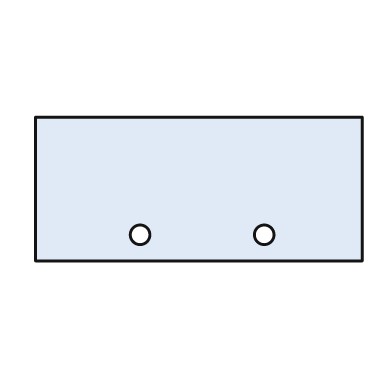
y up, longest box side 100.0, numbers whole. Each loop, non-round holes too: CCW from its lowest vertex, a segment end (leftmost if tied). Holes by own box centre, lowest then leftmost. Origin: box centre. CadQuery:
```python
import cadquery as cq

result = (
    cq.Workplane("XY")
    .moveTo(-50.0, -22.0)
    .lineTo(50.0, -22.0)
    .lineTo(50.0, 22.0)
    .lineTo(-50.0, 22.0)
    .close()
    .moveTo(-18.0, -14.0)
    .circle(3.0)
    .moveTo(20.0, -14.0)
    .circle(3.0)
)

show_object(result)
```